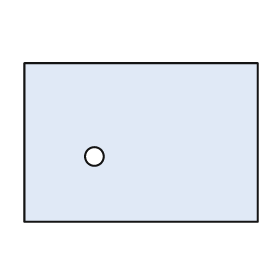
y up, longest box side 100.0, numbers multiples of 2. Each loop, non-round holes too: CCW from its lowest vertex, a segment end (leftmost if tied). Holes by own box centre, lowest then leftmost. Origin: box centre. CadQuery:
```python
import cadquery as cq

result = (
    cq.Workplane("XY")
    .moveTo(-50.0, -34.0)
    .lineTo(50.0, -34.0)
    .lineTo(50.0, 34.0)
    .lineTo(-50.0, 34.0)
    .close()
    .moveTo(-20.0, -6.0)
    .circle(4.0)
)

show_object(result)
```